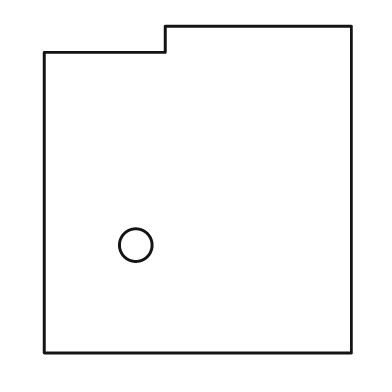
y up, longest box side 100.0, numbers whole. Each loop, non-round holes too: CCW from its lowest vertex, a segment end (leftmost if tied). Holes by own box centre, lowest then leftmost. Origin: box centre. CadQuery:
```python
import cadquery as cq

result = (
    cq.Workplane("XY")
    .moveTo(-47.0, -50.0)
    .lineTo(47.0, -50.0)
    .lineTo(47.0, 50.0)
    .lineTo(-10.0, 50.0)
    .lineTo(-10.0, 42.0)
    .lineTo(-47.0, 42.0)
    .close()
    .moveTo(-19.0, -17.0)
    .circle(5.0)
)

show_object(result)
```